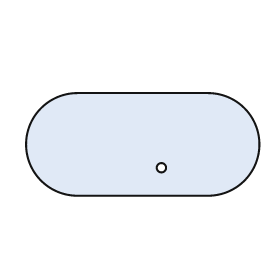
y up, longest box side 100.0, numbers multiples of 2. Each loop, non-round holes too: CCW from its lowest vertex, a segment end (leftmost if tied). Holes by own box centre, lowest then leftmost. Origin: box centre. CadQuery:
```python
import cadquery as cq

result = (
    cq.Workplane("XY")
    .moveTo(-28.0, -22.0)
    .lineTo(28.0, -22.0)
    .threePointArc((50.0, 0.0), (28.0, 22.0))
    .lineTo(-28.0, 22.0)
    .threePointArc((-50.0, 0.0), (-28.0, -22.0))
    .close()
    .moveTo(8.0, -10.0)
    .circle(2.0)
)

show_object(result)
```